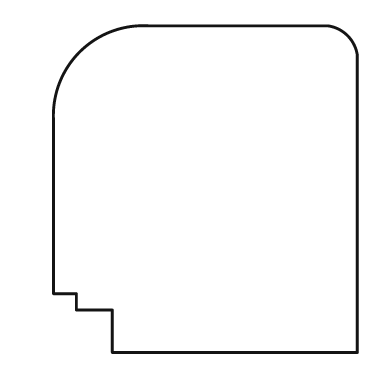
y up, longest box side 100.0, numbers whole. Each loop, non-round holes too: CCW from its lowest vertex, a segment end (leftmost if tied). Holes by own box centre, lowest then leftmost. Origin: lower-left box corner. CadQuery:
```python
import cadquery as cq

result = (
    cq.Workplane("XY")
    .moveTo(18.0, 0.0)
    .lineTo(93.0, 0.0)
    .lineTo(93.0, 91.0)
    .threePointArc((90.0, 97.0), (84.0, 100.0))
    .lineTo(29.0, 100.0)
    .threePointArc((8.0, 92.0), (0.0, 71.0))
    .lineTo(0.0, 18.0)
    .lineTo(7.0, 18.0)
    .lineTo(7.0, 13.0)
    .lineTo(18.0, 13.0)
    .close()
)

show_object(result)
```